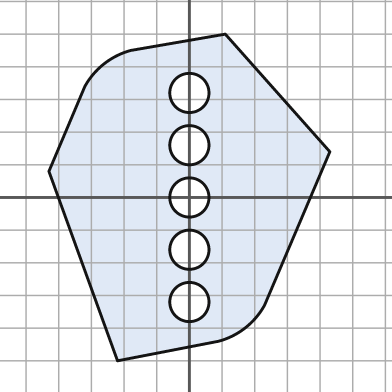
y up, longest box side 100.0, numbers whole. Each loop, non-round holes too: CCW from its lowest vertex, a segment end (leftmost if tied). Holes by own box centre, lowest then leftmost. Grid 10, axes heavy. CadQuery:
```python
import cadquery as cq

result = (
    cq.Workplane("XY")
    .moveTo(-22.0, -50.0)
    .lineTo(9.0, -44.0)
    .threePointArc((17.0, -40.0), (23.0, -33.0))
    .lineTo(43.0, 14.0)
    .lineTo(11.0, 50.0)
    .lineTo(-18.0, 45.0)
    .threePointArc((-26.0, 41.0), (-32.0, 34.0))
    .lineTo(-43.0, 8.0)
    .close()
    .moveTo(0.0, -32.0)
    .circle(6.0)
    .moveTo(0.0, -16.0)
    .circle(6.0)
    .moveTo(0.0, 0.0)
    .circle(6.0)
    .moveTo(0.0, 16.0)
    .circle(6.0)
    .moveTo(0.0, 32.0)
    .circle(6.0)
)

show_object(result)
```